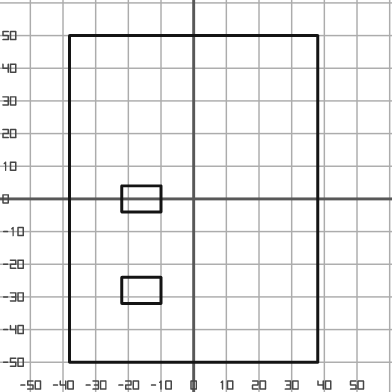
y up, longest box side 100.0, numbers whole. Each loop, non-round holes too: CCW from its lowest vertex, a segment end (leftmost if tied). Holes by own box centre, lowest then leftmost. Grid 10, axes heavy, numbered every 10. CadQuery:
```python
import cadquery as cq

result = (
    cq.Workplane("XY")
    .moveTo(-38.0, -50.0)
    .lineTo(38.0, -50.0)
    .lineTo(38.0, 50.0)
    .lineTo(-38.0, 50.0)
    .close()
    .moveTo(-22.0, -32.0)
    .lineTo(-10.0, -32.0)
    .lineTo(-10.0, -24.0)
    .lineTo(-22.0, -24.0)
    .close()
    .moveTo(-22.0, -4.0)
    .lineTo(-10.0, -4.0)
    .lineTo(-10.0, 4.0)
    .lineTo(-22.0, 4.0)
    .close()
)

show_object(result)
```